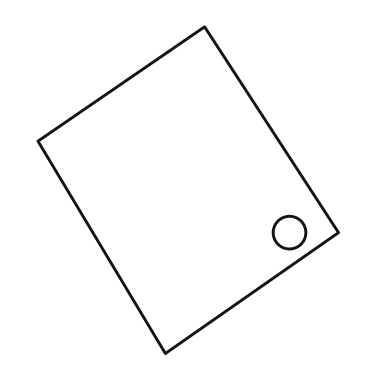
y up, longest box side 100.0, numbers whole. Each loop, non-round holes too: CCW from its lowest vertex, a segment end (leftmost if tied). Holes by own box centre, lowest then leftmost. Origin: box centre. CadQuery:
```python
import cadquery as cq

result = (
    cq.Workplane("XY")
    .moveTo(-7.0, -50.0)
    .lineTo(46.0, -13.0)
    .lineTo(5.0, 50.0)
    .lineTo(-46.0, 15.0)
    .close()
    .moveTo(31.0, -13.0)
    .circle(5.0)
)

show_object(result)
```